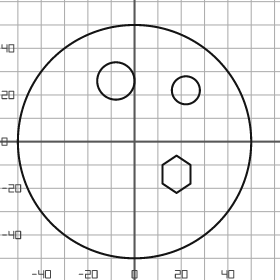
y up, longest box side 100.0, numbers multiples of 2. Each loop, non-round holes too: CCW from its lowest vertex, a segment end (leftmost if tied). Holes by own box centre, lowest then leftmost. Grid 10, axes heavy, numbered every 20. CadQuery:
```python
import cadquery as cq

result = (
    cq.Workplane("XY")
    .moveTo(0.0, 0.0)
    .circle(50.0)
    .moveTo(18.0, -22.0)
    .lineTo(24.0, -18.0)
    .lineTo(24.0, -10.0)
    .lineTo(18.0, -6.0)
    .lineTo(12.0, -10.0)
    .lineTo(12.0, -18.0)
    .close()
    .moveTo(22.0, 22.0)
    .circle(6.0)
    .moveTo(-8.0, 26.0)
    .circle(8.0)
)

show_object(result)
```